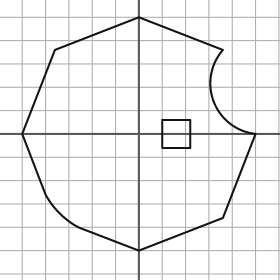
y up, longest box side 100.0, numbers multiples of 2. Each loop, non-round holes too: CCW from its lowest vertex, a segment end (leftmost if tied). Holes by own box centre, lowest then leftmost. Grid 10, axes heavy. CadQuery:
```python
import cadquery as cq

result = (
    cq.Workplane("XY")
    .moveTo(0.0, -50.0)
    .lineTo(36.0, -36.0)
    .lineTo(50.0, 0.0)
    .threePointArc((32.0, 14.0), (36.0, 36.0))
    .lineTo(0.0, 50.0)
    .lineTo(-36.0, 36.0)
    .lineTo(-50.0, 0.0)
    .lineTo(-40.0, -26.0)
    .threePointArc((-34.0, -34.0), (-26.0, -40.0))
    .close()
    .moveTo(10.0, -6.0)
    .lineTo(22.0, -6.0)
    .lineTo(22.0, 6.0)
    .lineTo(10.0, 6.0)
    .close()
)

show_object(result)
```